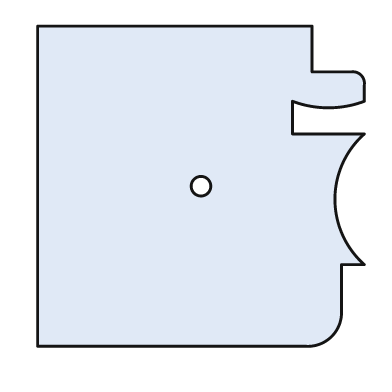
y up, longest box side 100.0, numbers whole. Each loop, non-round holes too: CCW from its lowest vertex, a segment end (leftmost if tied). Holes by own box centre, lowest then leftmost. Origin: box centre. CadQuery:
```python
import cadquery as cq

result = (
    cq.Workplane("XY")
    .moveTo(-50.0, -49.0)
    .lineTo(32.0, -49.0)
    .threePointArc((40.0, -46.0), (43.0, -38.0))
    .lineTo(43.0, -24.0)
    .lineTo(50.0, -24.0)
    .threePointArc((41.0, -4.0), (50.0, 16.0))
    .lineTo(28.0, 16.0)
    .lineTo(28.0, 26.0)
    .threePointArc((39.0, 24.0), (50.0, 26.0))
    .lineTo(50.0, 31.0)
    .threePointArc((49.0, 34.0), (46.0, 35.0))
    .lineTo(34.0, 35.0)
    .lineTo(34.0, 49.0)
    .lineTo(-50.0, 49.0)
    .close()
    .moveTo(0.0, 0.0)
    .circle(3.0)
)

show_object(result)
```